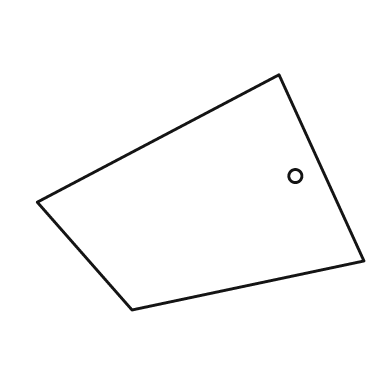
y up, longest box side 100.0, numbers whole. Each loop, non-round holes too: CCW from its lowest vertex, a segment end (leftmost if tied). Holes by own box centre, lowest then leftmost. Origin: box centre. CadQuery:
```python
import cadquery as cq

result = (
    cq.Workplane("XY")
    .moveTo(-21.0, -36.0)
    .lineTo(50.0, -21.0)
    .lineTo(24.0, 36.0)
    .lineTo(-50.0, -3.0)
    .close()
    .moveTo(29.0, 5.0)
    .circle(2.0)
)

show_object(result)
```